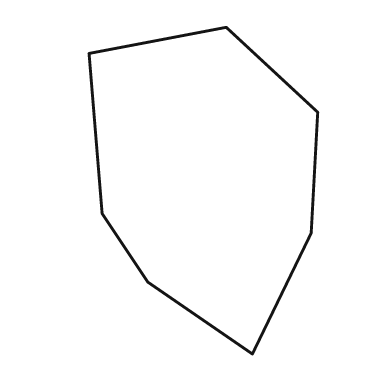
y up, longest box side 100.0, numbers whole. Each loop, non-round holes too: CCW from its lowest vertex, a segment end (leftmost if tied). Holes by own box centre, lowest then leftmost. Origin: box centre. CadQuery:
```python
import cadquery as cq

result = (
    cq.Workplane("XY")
    .moveTo(15.0, -50.0)
    .lineTo(33.0, -13.0)
    .lineTo(35.0, 24.0)
    .lineTo(7.0, 50.0)
    .lineTo(-35.0, 42.0)
    .lineTo(-31.0, -7.0)
    .lineTo(-17.0, -28.0)
    .close()
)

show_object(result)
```